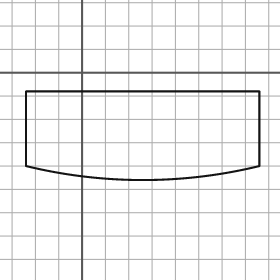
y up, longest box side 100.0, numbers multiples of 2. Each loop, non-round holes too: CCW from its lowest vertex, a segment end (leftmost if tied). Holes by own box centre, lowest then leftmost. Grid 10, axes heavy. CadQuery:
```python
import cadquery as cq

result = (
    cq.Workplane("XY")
    .moveTo(-24.0, -40.0)
    .threePointArc((26.0, -46.0), (76.0, -40.0))
    .lineTo(76.0, -8.0)
    .lineTo(-24.0, -8.0)
    .close()
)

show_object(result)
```